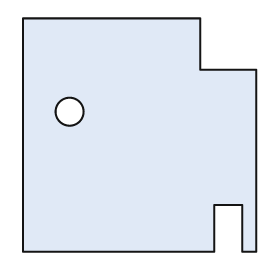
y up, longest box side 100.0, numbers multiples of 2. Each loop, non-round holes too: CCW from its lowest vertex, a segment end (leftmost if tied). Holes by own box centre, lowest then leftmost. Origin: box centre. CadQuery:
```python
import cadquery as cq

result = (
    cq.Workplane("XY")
    .moveTo(-50.0, -50.0)
    .lineTo(32.0, -50.0)
    .lineTo(32.0, -30.0)
    .lineTo(44.0, -30.0)
    .lineTo(44.0, -50.0)
    .lineTo(50.0, -50.0)
    .lineTo(50.0, 28.0)
    .lineTo(26.0, 28.0)
    .lineTo(26.0, 50.0)
    .lineTo(-50.0, 50.0)
    .close()
    .moveTo(-30.0, 10.0)
    .circle(6.0)
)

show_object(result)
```